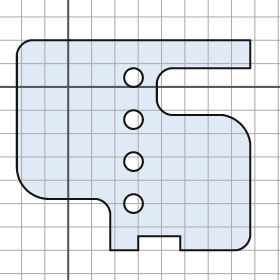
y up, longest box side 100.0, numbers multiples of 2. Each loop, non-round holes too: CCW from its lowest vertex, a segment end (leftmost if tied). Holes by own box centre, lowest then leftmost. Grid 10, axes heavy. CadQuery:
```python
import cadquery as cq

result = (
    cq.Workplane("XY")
    .moveTo(18.0, -70.0)
    .lineTo(30.0, -70.0)
    .lineTo(30.0, -64.0)
    .lineTo(48.0, -64.0)
    .lineTo(48.0, -70.0)
    .lineTo(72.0, -70.0)
    .threePointArc((76.0, -68.0), (78.0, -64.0))
    .lineTo(78.0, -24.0)
    .threePointArc((74.0, -16.0), (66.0, -12.0))
    .lineTo(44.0, -12.0)
    .threePointArc((40.0, -10.0), (38.0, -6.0))
    .lineTo(38.0, 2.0)
    .threePointArc((40.0, 6.0), (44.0, 8.0))
    .lineTo(78.0, 8.0)
    .lineTo(78.0, 20.0)
    .lineTo(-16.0, 20.0)
    .threePointArc((-20.0, 18.0), (-22.0, 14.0))
    .lineTo(-22.0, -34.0)
    .threePointArc((-18.0, -44.0), (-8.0, -48.0))
    .lineTo(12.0, -48.0)
    .threePointArc((16.0, -50.0), (18.0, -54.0))
    .close()
    .moveTo(28.0, -50.0)
    .circle(4.0)
    .moveTo(28.0, -32.0)
    .circle(4.0)
    .moveTo(28.0, -14.0)
    .circle(4.0)
    .moveTo(28.0, 4.0)
    .circle(4.0)
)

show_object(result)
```